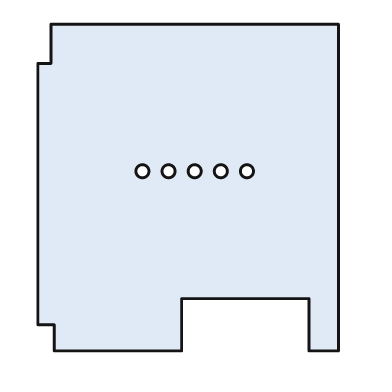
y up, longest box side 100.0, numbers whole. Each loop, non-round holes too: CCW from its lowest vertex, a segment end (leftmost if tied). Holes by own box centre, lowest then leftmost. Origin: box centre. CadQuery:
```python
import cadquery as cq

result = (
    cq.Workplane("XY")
    .moveTo(-41.0, -50.0)
    .lineTo(-2.0, -50.0)
    .lineTo(-2.0, -34.0)
    .lineTo(37.0, -34.0)
    .lineTo(37.0, -50.0)
    .lineTo(46.0, -50.0)
    .lineTo(46.0, 50.0)
    .lineTo(-42.0, 50.0)
    .lineTo(-42.0, 38.0)
    .lineTo(-46.0, 38.0)
    .lineTo(-46.0, -42.0)
    .lineTo(-41.0, -42.0)
    .close()
    .moveTo(-14.0, 5.0)
    .circle(2.0)
    .moveTo(-6.0, 5.0)
    .circle(2.0)
    .moveTo(2.0, 5.0)
    .circle(2.0)
    .moveTo(10.0, 5.0)
    .circle(2.0)
    .moveTo(18.0, 5.0)
    .circle(2.0)
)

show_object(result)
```